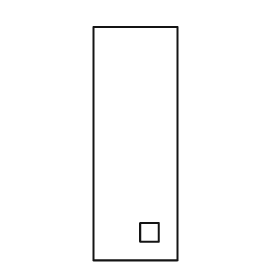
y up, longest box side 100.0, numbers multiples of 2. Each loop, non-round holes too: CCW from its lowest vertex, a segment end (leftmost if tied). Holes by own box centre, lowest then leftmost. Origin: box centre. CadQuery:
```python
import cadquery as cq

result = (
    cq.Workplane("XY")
    .moveTo(-18.0, -50.0)
    .lineTo(18.0, -50.0)
    .lineTo(18.0, 50.0)
    .lineTo(-18.0, 50.0)
    .close()
    .moveTo(2.0, -42.0)
    .lineTo(10.0, -42.0)
    .lineTo(10.0, -34.0)
    .lineTo(2.0, -34.0)
    .close()
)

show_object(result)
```